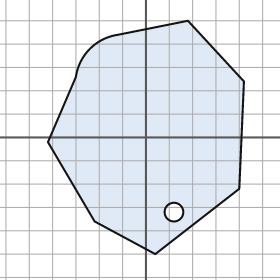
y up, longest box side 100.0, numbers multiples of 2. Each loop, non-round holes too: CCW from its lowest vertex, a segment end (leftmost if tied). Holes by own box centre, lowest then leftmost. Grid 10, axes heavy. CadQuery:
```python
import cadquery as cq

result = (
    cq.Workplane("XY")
    .moveTo(4.0, -50.0)
    .lineTo(40.0, -22.0)
    .lineTo(42.0, 24.0)
    .lineTo(18.0, 50.0)
    .lineTo(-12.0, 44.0)
    .threePointArc((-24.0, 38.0), (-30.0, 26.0))
    .lineTo(-42.0, -2.0)
    .lineTo(-22.0, -36.0)
    .close()
    .moveTo(12.0, -32.0)
    .circle(4.0)
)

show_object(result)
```